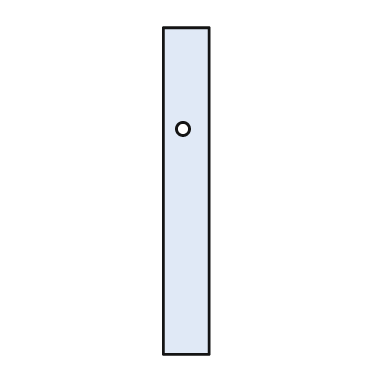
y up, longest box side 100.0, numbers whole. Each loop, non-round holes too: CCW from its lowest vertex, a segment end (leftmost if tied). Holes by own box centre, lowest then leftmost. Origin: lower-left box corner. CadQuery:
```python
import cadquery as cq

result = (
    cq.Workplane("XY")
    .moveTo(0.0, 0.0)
    .lineTo(14.0, 0.0)
    .lineTo(14.0, 100.0)
    .lineTo(0.0, 100.0)
    .close()
    .moveTo(6.0, 69.0)
    .circle(2.0)
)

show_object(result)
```